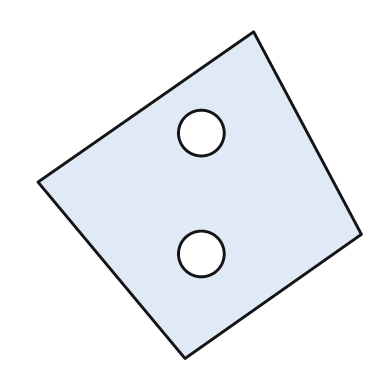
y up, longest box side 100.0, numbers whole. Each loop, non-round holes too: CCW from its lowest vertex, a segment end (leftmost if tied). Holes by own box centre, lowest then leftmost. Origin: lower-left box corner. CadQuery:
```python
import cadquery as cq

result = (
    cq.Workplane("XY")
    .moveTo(45.0, 0.0)
    .lineTo(99.0, 38.0)
    .lineTo(66.0, 100.0)
    .lineTo(0.0, 54.0)
    .close()
    .moveTo(50.0, 32.0)
    .circle(7.0)
    .moveTo(50.0, 69.0)
    .circle(7.0)
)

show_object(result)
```